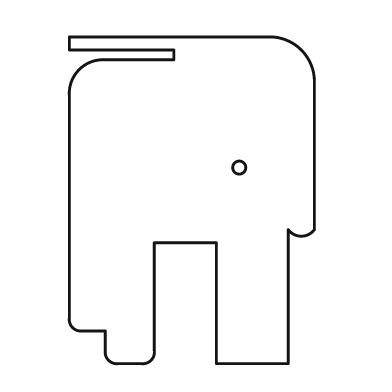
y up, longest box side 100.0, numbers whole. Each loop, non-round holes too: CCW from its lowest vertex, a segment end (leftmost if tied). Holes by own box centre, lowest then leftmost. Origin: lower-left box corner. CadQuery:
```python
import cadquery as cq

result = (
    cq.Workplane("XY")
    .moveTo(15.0, 0.0)
    .lineTo(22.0, 0.0)
    .threePointArc((25.0, 1.0), (26.0, 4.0))
    .lineTo(26.0, 37.0)
    .lineTo(45.0, 37.0)
    .lineTo(45.0, 0.0)
    .lineTo(67.0, 0.0)
    .lineTo(67.0, 41.0)
    .threePointArc((71.0, 39.0), (75.0, 41.0))
    .lineTo(75.0, 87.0)
    .threePointArc((71.0, 96.0), (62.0, 100.0))
    .lineTo(0.0, 100.0)
    .lineTo(0.0, 96.0)
    .lineTo(32.0, 96.0)
    .lineTo(32.0, 93.0)
    .lineTo(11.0, 93.0)
    .threePointArc((3.0, 90.0), (0.0, 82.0))
    .lineTo(0.0, 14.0)
    .threePointArc((1.0, 11.0), (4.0, 10.0))
    .lineTo(11.0, 10.0)
    .lineTo(11.0, 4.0)
    .threePointArc((12.0, 1.0), (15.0, 0.0))
    .close()
    .moveTo(52.0, 60.0)
    .circle(2.0)
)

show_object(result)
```